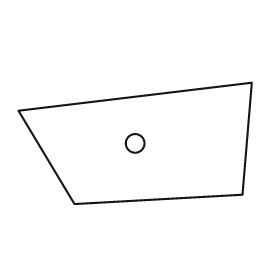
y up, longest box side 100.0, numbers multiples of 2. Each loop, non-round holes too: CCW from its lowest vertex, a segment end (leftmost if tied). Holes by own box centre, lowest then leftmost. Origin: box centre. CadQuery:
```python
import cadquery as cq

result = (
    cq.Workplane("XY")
    .moveTo(-26.0, -26.0)
    .lineTo(46.0, -22.0)
    .lineTo(50.0, 26.0)
    .lineTo(-50.0, 14.0)
    .close()
    .moveTo(0.0, 0.0)
    .circle(4.0)
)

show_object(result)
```